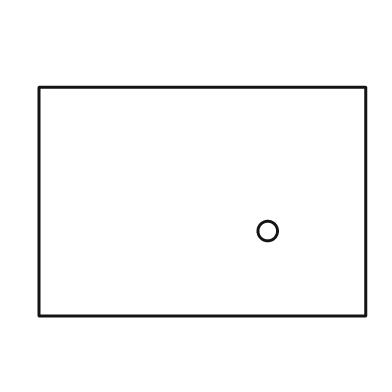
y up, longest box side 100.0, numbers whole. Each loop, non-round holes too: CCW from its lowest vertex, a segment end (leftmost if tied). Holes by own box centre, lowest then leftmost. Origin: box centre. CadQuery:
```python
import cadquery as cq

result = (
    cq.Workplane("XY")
    .moveTo(-50.0, -35.0)
    .lineTo(50.0, -35.0)
    .lineTo(50.0, 35.0)
    .lineTo(-50.0, 35.0)
    .close()
    .moveTo(20.0, -9.0)
    .circle(3.0)
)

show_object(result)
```